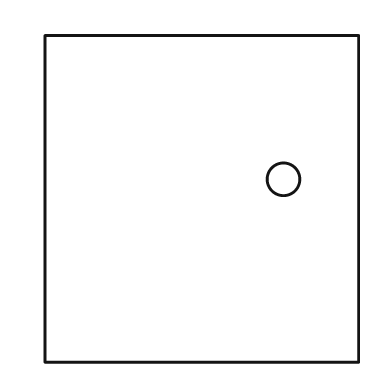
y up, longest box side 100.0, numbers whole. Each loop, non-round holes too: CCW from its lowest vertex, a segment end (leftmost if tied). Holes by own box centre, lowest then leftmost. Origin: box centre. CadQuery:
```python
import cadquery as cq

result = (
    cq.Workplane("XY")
    .moveTo(-48.0, -50.0)
    .lineTo(48.0, -50.0)
    .lineTo(48.0, 50.0)
    .lineTo(-48.0, 50.0)
    .close()
    .moveTo(25.0, 6.0)
    .circle(5.0)
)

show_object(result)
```